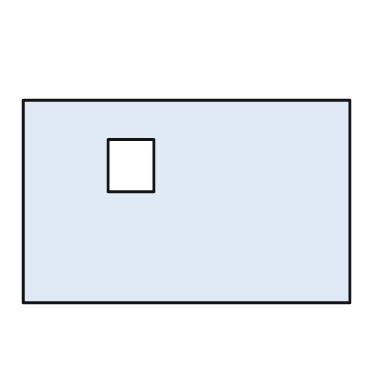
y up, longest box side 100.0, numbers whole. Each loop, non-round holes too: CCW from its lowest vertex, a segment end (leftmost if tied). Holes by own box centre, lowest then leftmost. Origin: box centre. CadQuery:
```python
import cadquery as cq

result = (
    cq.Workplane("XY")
    .moveTo(-50.0, -31.0)
    .lineTo(50.0, -31.0)
    .lineTo(50.0, 31.0)
    .lineTo(-50.0, 31.0)
    .close()
    .moveTo(-24.0, 3.0)
    .lineTo(-10.0, 3.0)
    .lineTo(-10.0, 19.0)
    .lineTo(-24.0, 19.0)
    .close()
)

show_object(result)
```